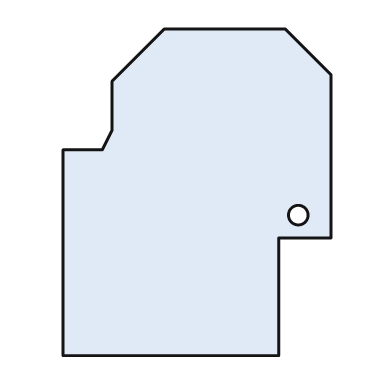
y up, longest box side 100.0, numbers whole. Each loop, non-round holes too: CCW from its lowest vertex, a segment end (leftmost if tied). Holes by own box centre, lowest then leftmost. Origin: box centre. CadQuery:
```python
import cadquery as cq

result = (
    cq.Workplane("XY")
    .moveTo(-41.0, -50.0)
    .lineTo(25.0, -50.0)
    .lineTo(25.0, -14.0)
    .lineTo(41.0, -14.0)
    .lineTo(41.0, 36.0)
    .lineTo(27.0, 50.0)
    .lineTo(-10.0, 50.0)
    .lineTo(-26.0, 34.0)
    .lineTo(-26.0, 19.0)
    .lineTo(-29.0, 13.0)
    .lineTo(-41.0, 13.0)
    .close()
    .moveTo(31.0, -7.0)
    .circle(3.0)
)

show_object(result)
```